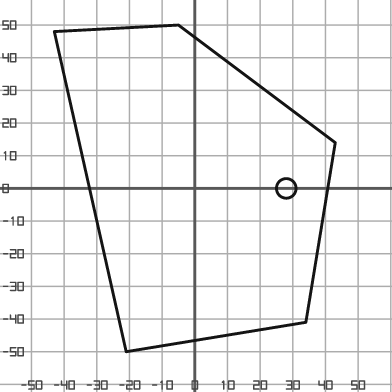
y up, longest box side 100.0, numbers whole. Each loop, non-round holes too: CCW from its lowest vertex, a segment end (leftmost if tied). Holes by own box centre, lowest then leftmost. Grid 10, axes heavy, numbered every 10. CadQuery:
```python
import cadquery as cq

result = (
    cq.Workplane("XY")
    .moveTo(-21.0, -50.0)
    .lineTo(34.0, -41.0)
    .lineTo(43.0, 14.0)
    .lineTo(-5.0, 50.0)
    .lineTo(-43.0, 48.0)
    .close()
    .moveTo(28.0, 0.0)
    .circle(3.0)
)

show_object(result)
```